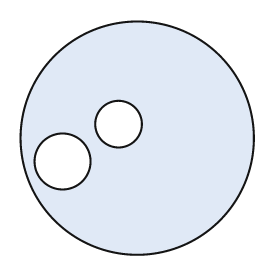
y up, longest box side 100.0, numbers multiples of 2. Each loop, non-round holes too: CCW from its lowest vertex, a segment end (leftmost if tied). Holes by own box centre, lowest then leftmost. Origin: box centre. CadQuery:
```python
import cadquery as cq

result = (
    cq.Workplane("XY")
    .moveTo(0.0, 0.0)
    .circle(50.0)
    .moveTo(-32.0, -10.0)
    .circle(12.0)
    .moveTo(-8.0, 6.0)
    .circle(10.0)
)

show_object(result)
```